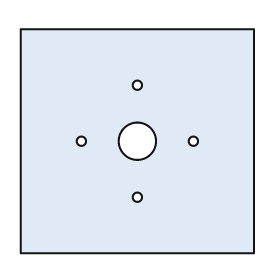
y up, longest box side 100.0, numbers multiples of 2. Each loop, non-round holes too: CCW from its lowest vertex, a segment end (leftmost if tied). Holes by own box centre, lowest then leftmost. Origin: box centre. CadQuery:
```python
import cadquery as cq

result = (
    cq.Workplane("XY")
    .moveTo(-50.0, -48.0)
    .lineTo(50.0, -48.0)
    .lineTo(50.0, 48.0)
    .lineTo(-50.0, 48.0)
    .close()
    .moveTo(0.0, -24.0)
    .circle(2.0)
    .moveTo(-24.0, 0.0)
    .circle(2.0)
    .moveTo(0.0, 0.0)
    .circle(8.0)
    .moveTo(24.0, 0.0)
    .circle(2.0)
    .moveTo(0.0, 24.0)
    .circle(2.0)
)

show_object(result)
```